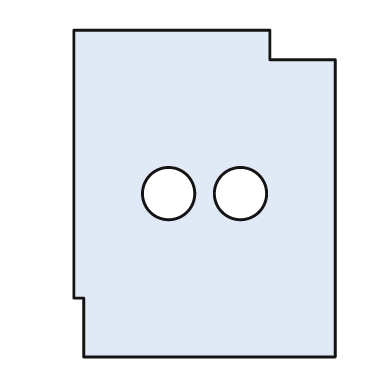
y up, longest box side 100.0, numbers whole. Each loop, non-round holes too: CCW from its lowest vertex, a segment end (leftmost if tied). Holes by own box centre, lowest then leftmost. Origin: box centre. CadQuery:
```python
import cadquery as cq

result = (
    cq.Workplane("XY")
    .moveTo(-37.0, -50.0)
    .lineTo(40.0, -50.0)
    .lineTo(40.0, 41.0)
    .lineTo(20.0, 41.0)
    .lineTo(20.0, 50.0)
    .lineTo(-40.0, 50.0)
    .lineTo(-40.0, -32.0)
    .lineTo(-37.0, -32.0)
    .close()
    .moveTo(-11.0, 0.0)
    .circle(8.0)
    .moveTo(11.0, 0.0)
    .circle(8.0)
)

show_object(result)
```